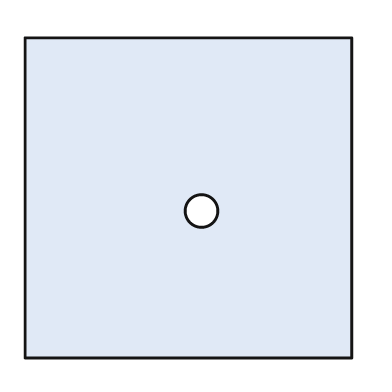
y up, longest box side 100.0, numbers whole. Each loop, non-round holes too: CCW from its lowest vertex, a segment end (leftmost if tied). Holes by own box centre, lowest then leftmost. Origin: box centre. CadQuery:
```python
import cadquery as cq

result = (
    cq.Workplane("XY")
    .moveTo(-50.0, -49.0)
    .lineTo(50.0, -49.0)
    .lineTo(50.0, 49.0)
    .lineTo(-50.0, 49.0)
    .close()
    .moveTo(4.0, -4.0)
    .circle(5.0)
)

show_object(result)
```